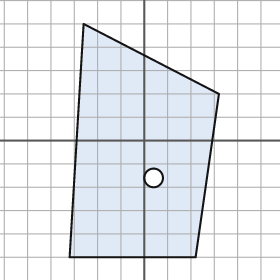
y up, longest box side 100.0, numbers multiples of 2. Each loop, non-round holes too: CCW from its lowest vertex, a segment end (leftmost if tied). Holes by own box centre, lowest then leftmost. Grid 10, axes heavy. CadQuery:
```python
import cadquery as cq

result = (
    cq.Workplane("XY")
    .moveTo(-32.0, -50.0)
    .lineTo(22.0, -50.0)
    .lineTo(32.0, 20.0)
    .lineTo(-26.0, 50.0)
    .close()
    .moveTo(4.0, -16.0)
    .circle(4.0)
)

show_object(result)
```